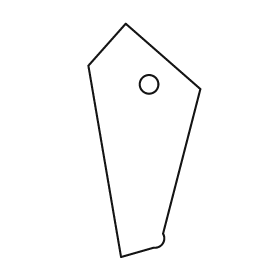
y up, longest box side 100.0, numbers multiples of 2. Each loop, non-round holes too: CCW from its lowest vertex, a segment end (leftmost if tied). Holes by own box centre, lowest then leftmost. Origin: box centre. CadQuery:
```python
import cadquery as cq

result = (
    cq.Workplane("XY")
    .moveTo(-10.0, -50.0)
    .lineTo(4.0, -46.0)
    .threePointArc((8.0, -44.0), (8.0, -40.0))
    .lineTo(24.0, 22.0)
    .lineTo(-8.0, 50.0)
    .lineTo(-24.0, 32.0)
    .close()
    .moveTo(2.0, 24.0)
    .circle(4.0)
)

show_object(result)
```